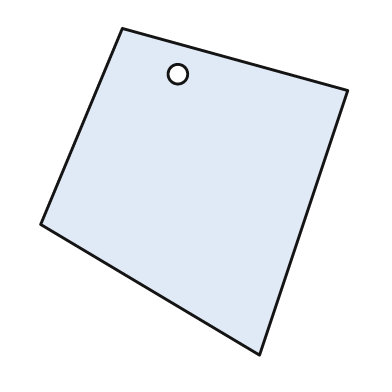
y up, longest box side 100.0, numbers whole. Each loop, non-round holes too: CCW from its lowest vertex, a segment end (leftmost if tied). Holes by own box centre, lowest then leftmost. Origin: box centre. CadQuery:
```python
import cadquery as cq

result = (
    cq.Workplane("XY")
    .moveTo(20.0, -50.0)
    .lineTo(47.0, 31.0)
    .lineTo(-22.0, 50.0)
    .lineTo(-47.0, -10.0)
    .close()
    .moveTo(-5.0, 36.0)
    .circle(3.0)
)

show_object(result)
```